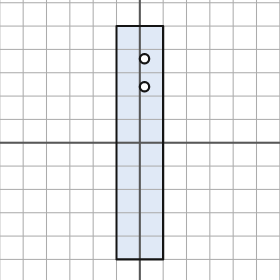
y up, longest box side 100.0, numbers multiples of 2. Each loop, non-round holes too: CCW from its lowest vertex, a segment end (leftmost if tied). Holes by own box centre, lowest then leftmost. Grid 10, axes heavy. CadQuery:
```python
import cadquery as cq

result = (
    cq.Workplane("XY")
    .moveTo(-10.0, -50.0)
    .lineTo(10.0, -50.0)
    .lineTo(10.0, 50.0)
    .lineTo(-10.0, 50.0)
    .close()
    .moveTo(2.0, 24.0)
    .circle(2.0)
    .moveTo(2.0, 36.0)
    .circle(2.0)
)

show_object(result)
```